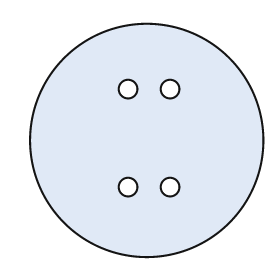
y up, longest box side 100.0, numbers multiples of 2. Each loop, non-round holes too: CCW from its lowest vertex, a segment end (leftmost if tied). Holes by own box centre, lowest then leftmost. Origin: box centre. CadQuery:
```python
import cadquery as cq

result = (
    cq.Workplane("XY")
    .moveTo(0.0, 0.0)
    .circle(50.0)
    .moveTo(-8.0, -20.0)
    .circle(4.0)
    .moveTo(10.0, -20.0)
    .circle(4.0)
    .moveTo(-8.0, 22.0)
    .circle(4.0)
    .moveTo(10.0, 22.0)
    .circle(4.0)
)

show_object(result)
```